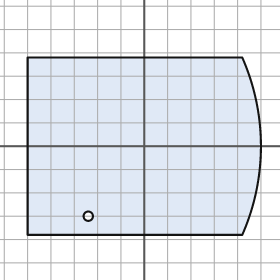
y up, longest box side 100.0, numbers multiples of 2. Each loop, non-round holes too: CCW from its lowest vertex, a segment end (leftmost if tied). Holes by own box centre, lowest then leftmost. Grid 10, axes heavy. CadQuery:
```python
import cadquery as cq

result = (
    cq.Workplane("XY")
    .moveTo(-50.0, -38.0)
    .lineTo(42.0, -38.0)
    .threePointArc((50.0, 0.0), (42.0, 38.0))
    .lineTo(-50.0, 38.0)
    .close()
    .moveTo(-24.0, -30.0)
    .circle(2.0)
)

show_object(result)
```